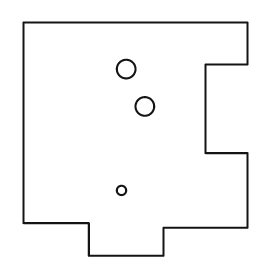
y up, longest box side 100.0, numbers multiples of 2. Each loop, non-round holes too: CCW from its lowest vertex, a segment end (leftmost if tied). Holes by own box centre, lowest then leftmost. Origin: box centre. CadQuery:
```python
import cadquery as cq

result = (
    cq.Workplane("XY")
    .moveTo(-20.0, -50.0)
    .lineTo(12.0, -50.0)
    .lineTo(12.0, -38.0)
    .lineTo(48.0, -38.0)
    .lineTo(48.0, -6.0)
    .lineTo(30.0, -6.0)
    .lineTo(30.0, 32.0)
    .lineTo(48.0, 32.0)
    .lineTo(48.0, 50.0)
    .lineTo(-48.0, 50.0)
    .lineTo(-48.0, -36.0)
    .lineTo(-20.0, -36.0)
    .close()
    .moveTo(-6.0, -22.0)
    .circle(2.0)
    .moveTo(4.0, 14.0)
    .circle(4.0)
    .moveTo(-4.0, 30.0)
    .circle(4.0)
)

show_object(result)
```